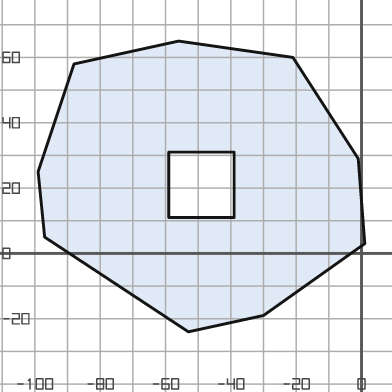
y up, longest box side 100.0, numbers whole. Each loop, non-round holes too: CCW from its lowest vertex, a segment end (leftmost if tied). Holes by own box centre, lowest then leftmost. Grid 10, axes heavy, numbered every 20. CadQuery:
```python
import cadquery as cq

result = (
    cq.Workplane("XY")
    .moveTo(-53.0, -24.0)
    .lineTo(-30.0, -19.0)
    .lineTo(1.0, 3.0)
    .lineTo(-1.0, 29.0)
    .lineTo(-21.0, 60.0)
    .lineTo(-56.0, 65.0)
    .lineTo(-88.0, 58.0)
    .lineTo(-99.0, 25.0)
    .lineTo(-97.0, 5.0)
    .close()
    .moveTo(-59.0, 11.0)
    .lineTo(-39.0, 11.0)
    .lineTo(-39.0, 31.0)
    .lineTo(-59.0, 31.0)
    .close()
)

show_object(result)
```